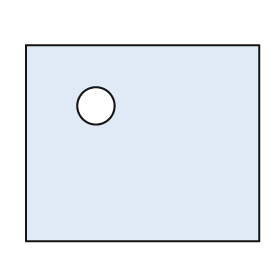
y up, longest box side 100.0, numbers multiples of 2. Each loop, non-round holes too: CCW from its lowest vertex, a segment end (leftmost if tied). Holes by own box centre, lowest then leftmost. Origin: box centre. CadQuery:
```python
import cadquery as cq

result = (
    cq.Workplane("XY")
    .moveTo(-50.0, -42.0)
    .lineTo(50.0, -42.0)
    .lineTo(50.0, 42.0)
    .lineTo(-50.0, 42.0)
    .close()
    .moveTo(-20.0, 16.0)
    .circle(8.0)
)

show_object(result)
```